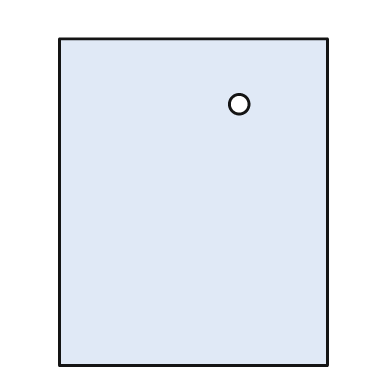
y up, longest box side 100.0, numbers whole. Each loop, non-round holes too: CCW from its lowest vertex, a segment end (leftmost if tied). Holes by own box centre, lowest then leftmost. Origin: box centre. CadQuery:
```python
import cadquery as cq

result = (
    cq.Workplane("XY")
    .moveTo(-41.0, -50.0)
    .lineTo(41.0, -50.0)
    .lineTo(41.0, 50.0)
    .lineTo(-41.0, 50.0)
    .close()
    .moveTo(14.0, 30.0)
    .circle(3.0)
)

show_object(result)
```